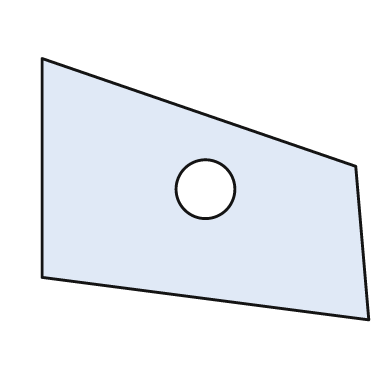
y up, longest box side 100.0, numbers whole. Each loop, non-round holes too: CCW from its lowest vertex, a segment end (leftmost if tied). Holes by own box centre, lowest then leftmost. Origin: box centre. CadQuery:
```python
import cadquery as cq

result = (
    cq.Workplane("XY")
    .moveTo(50.0, -40.0)
    .lineTo(46.0, 7.0)
    .lineTo(-50.0, 40.0)
    .lineTo(-50.0, -27.0)
    .close()
    .moveTo(0.0, 0.0)
    .circle(9.0)
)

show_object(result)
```